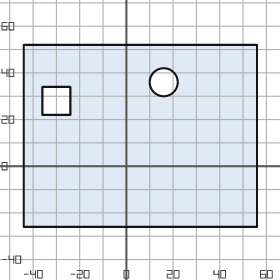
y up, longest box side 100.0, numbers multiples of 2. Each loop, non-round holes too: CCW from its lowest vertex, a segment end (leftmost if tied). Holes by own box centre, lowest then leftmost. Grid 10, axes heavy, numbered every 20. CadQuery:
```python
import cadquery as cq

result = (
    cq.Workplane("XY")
    .moveTo(-44.0, -26.0)
    .lineTo(56.0, -26.0)
    .lineTo(56.0, 52.0)
    .lineTo(-44.0, 52.0)
    .close()
    .moveTo(-36.0, 22.0)
    .lineTo(-24.0, 22.0)
    .lineTo(-24.0, 34.0)
    .lineTo(-36.0, 34.0)
    .close()
    .moveTo(16.0, 36.0)
    .circle(6.0)
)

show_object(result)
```